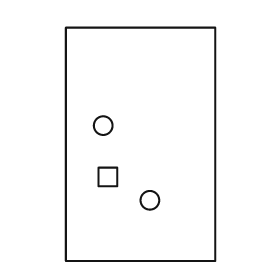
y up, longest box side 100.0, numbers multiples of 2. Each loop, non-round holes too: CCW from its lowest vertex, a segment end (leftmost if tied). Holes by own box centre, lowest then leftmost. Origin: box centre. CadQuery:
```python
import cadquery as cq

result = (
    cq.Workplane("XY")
    .moveTo(-32.0, -50.0)
    .lineTo(32.0, -50.0)
    .lineTo(32.0, 50.0)
    .lineTo(-32.0, 50.0)
    .close()
    .moveTo(4.0, -24.0)
    .circle(4.0)
    .moveTo(-18.0, -18.0)
    .lineTo(-10.0, -18.0)
    .lineTo(-10.0, -10.0)
    .lineTo(-18.0, -10.0)
    .close()
    .moveTo(-16.0, 8.0)
    .circle(4.0)
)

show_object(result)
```